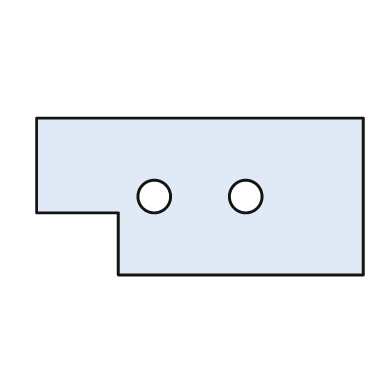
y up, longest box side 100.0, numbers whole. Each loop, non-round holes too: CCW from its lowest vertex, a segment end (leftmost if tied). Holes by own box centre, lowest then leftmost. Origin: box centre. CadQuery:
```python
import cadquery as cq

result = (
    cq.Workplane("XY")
    .moveTo(-25.0, -24.0)
    .lineTo(50.0, -24.0)
    .lineTo(50.0, 24.0)
    .lineTo(-50.0, 24.0)
    .lineTo(-50.0, -5.0)
    .lineTo(-25.0, -5.0)
    .close()
    .moveTo(-14.0, 0.0)
    .circle(5.0)
    .moveTo(14.0, 0.0)
    .circle(5.0)
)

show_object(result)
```